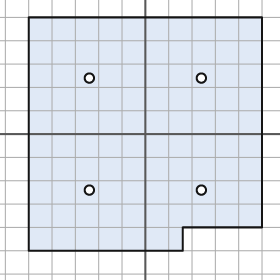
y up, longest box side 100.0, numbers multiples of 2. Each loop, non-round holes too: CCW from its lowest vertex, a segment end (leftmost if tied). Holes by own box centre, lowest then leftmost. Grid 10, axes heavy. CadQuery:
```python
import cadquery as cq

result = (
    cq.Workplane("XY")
    .moveTo(-50.0, -50.0)
    .lineTo(16.0, -50.0)
    .lineTo(16.0, -40.0)
    .lineTo(50.0, -40.0)
    .lineTo(50.0, 50.0)
    .lineTo(-50.0, 50.0)
    .close()
    .moveTo(-24.0, -24.0)
    .circle(2.0)
    .moveTo(24.0, -24.0)
    .circle(2.0)
    .moveTo(-24.0, 24.0)
    .circle(2.0)
    .moveTo(24.0, 24.0)
    .circle(2.0)
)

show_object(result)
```